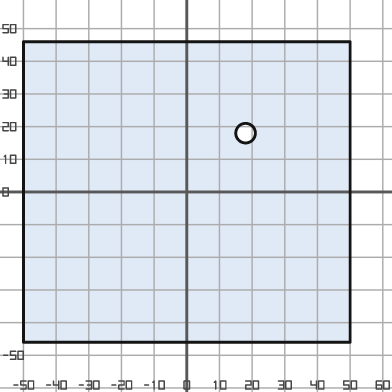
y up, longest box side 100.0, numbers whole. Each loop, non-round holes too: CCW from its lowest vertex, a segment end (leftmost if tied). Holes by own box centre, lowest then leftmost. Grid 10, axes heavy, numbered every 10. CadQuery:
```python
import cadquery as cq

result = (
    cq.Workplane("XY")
    .moveTo(-50.0, -46.0)
    .lineTo(50.0, -46.0)
    .lineTo(50.0, 46.0)
    .lineTo(-50.0, 46.0)
    .close()
    .moveTo(18.0, 18.0)
    .circle(3.0)
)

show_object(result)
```